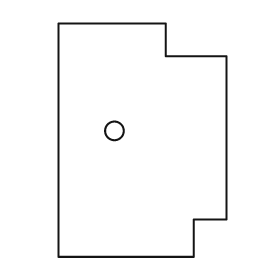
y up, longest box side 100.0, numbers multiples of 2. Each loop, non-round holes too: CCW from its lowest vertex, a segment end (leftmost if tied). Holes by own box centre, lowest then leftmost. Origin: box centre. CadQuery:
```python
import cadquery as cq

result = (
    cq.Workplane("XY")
    .moveTo(-36.0, -50.0)
    .lineTo(22.0, -50.0)
    .lineTo(22.0, -34.0)
    .lineTo(36.0, -34.0)
    .lineTo(36.0, 36.0)
    .lineTo(10.0, 36.0)
    .lineTo(10.0, 50.0)
    .lineTo(-36.0, 50.0)
    .close()
    .moveTo(-12.0, 4.0)
    .circle(4.0)
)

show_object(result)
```